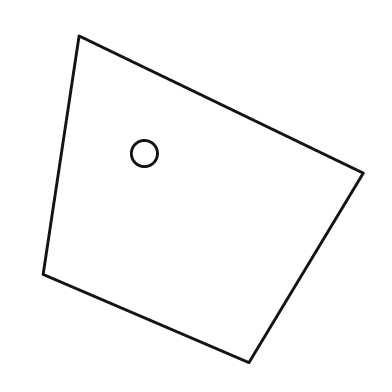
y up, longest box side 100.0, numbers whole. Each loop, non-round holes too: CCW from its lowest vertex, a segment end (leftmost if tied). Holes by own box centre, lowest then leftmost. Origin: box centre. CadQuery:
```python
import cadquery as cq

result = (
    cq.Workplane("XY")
    .moveTo(14.0, -50.0)
    .lineTo(49.0, 8.0)
    .lineTo(-38.0, 50.0)
    .lineTo(-49.0, -23.0)
    .close()
    .moveTo(-18.0, 14.0)
    .circle(4.0)
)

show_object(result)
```